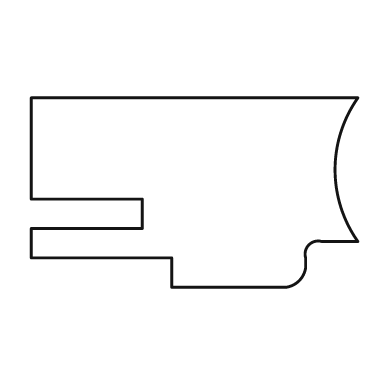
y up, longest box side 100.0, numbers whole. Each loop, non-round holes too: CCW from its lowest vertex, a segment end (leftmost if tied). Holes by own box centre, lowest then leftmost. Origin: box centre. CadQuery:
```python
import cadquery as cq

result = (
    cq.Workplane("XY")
    .moveTo(-7.0, -29.0)
    .lineTo(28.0, -29.0)
    .threePointArc((32.0, -27.0), (34.0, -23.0))
    .lineTo(34.0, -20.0)
    .threePointArc((35.0, -16.0), (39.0, -15.0))
    .lineTo(50.0, -15.0)
    .threePointArc((43.0, 7.0), (50.0, 29.0))
    .lineTo(-50.0, 29.0)
    .lineTo(-50.0, -2.0)
    .lineTo(-16.0, -2.0)
    .lineTo(-16.0, -11.0)
    .lineTo(-50.0, -11.0)
    .lineTo(-50.0, -20.0)
    .lineTo(-7.0, -20.0)
    .close()
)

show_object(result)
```